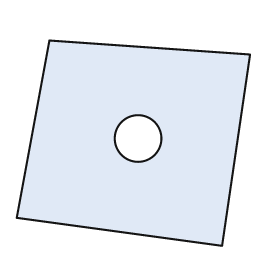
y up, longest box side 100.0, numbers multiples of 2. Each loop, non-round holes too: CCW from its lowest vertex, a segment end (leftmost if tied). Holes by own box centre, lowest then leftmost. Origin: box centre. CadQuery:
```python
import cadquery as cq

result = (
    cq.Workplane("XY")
    .moveTo(38.0, -44.0)
    .lineTo(50.0, 38.0)
    .lineTo(-36.0, 44.0)
    .lineTo(-50.0, -32.0)
    .close()
    .moveTo(2.0, 2.0)
    .circle(10.0)
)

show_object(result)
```